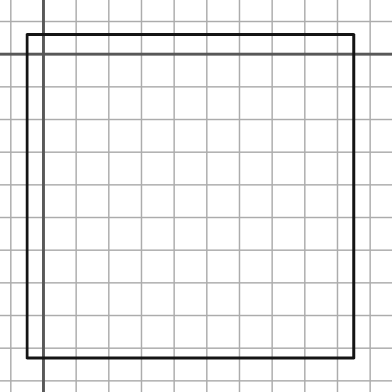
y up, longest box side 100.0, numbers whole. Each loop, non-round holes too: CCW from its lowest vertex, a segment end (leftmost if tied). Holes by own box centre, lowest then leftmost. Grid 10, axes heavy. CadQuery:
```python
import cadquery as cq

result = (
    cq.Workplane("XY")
    .moveTo(-5.0, -93.0)
    .lineTo(95.0, -93.0)
    .lineTo(95.0, 6.0)
    .lineTo(-5.0, 6.0)
    .close()
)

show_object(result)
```